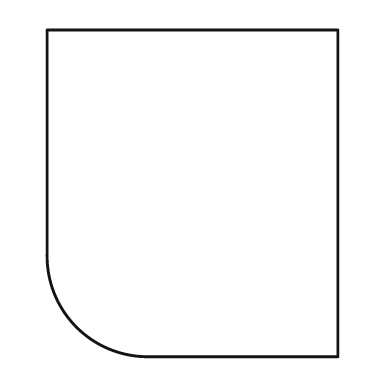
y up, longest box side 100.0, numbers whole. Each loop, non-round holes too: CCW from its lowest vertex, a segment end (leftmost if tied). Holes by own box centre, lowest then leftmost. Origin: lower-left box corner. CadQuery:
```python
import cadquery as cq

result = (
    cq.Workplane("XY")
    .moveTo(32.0, 0.0)
    .lineTo(89.0, 0.0)
    .lineTo(89.0, 100.0)
    .lineTo(0.0, 100.0)
    .lineTo(0.0, 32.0)
    .threePointArc((9.0, 9.0), (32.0, 0.0))
    .close()
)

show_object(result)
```